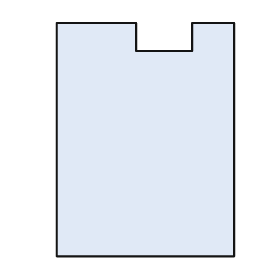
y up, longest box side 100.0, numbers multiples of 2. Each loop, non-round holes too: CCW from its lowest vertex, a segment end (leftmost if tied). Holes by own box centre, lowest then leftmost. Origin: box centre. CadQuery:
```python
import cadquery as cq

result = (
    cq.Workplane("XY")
    .moveTo(-38.0, -50.0)
    .lineTo(38.0, -50.0)
    .lineTo(38.0, 50.0)
    .lineTo(20.0, 50.0)
    .lineTo(20.0, 38.0)
    .lineTo(-4.0, 38.0)
    .lineTo(-4.0, 50.0)
    .lineTo(-38.0, 50.0)
    .close()
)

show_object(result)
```